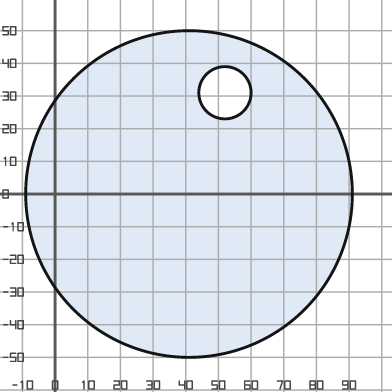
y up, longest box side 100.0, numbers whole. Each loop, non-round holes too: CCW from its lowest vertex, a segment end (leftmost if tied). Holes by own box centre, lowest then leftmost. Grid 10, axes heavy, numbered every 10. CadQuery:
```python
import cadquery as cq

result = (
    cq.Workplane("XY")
    .moveTo(41.0, 0.0)
    .circle(50.0)
    .moveTo(52.0, 31.0)
    .circle(8.0)
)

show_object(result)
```